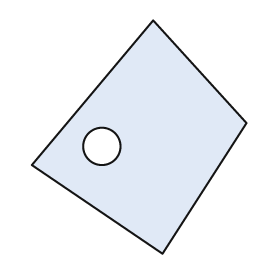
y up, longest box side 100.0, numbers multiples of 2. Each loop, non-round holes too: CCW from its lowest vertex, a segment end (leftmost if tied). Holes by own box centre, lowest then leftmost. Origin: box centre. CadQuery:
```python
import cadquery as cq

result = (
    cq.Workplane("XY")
    .moveTo(10.0, -50.0)
    .lineTo(46.0, 6.0)
    .lineTo(6.0, 50.0)
    .lineTo(-46.0, -12.0)
    .close()
    .moveTo(-16.0, -4.0)
    .circle(8.0)
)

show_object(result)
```